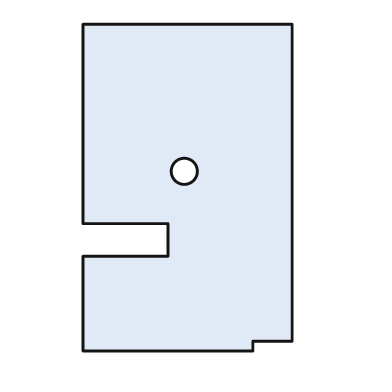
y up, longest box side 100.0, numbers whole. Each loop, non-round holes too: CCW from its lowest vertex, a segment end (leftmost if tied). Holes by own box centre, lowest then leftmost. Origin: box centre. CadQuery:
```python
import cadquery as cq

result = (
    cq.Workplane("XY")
    .moveTo(-32.0, -50.0)
    .lineTo(20.0, -50.0)
    .lineTo(20.0, -47.0)
    .lineTo(32.0, -47.0)
    .lineTo(32.0, 50.0)
    .lineTo(-32.0, 50.0)
    .lineTo(-32.0, -11.0)
    .lineTo(-6.0, -11.0)
    .lineTo(-6.0, -21.0)
    .lineTo(-32.0, -21.0)
    .close()
    .moveTo(-1.0, 5.0)
    .circle(4.0)
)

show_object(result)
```